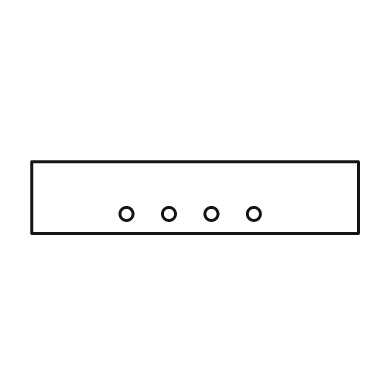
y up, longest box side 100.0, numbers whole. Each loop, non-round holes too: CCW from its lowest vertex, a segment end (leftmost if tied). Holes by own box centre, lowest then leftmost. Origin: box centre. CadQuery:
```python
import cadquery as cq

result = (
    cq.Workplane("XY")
    .moveTo(-50.0, -11.0)
    .lineTo(50.0, -11.0)
    .lineTo(50.0, 11.0)
    .lineTo(-50.0, 11.0)
    .close()
    .moveTo(-21.0, -5.0)
    .circle(2.0)
    .moveTo(-8.0, -5.0)
    .circle(2.0)
    .moveTo(5.0, -5.0)
    .circle(2.0)
    .moveTo(18.0, -5.0)
    .circle(2.0)
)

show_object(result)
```